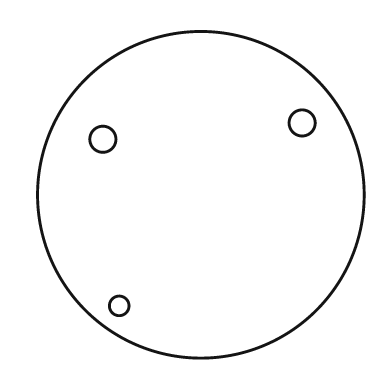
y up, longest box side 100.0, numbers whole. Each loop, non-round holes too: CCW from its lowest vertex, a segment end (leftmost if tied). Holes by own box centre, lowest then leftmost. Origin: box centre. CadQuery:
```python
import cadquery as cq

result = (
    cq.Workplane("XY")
    .moveTo(0.0, 0.0)
    .circle(50.0)
    .moveTo(-25.0, -34.0)
    .circle(3.0)
    .moveTo(-30.0, 17.0)
    .circle(4.0)
    .moveTo(31.0, 22.0)
    .circle(4.0)
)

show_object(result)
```